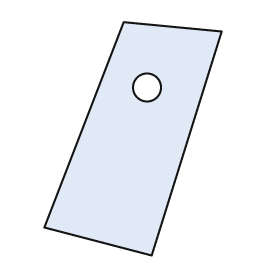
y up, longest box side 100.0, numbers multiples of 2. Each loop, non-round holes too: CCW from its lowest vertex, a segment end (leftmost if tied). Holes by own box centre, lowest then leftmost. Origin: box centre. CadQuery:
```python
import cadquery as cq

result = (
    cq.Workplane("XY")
    .moveTo(8.0, -50.0)
    .lineTo(38.0, 46.0)
    .lineTo(-4.0, 50.0)
    .lineTo(-38.0, -38.0)
    .close()
    .moveTo(6.0, 22.0)
    .circle(6.0)
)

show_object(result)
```